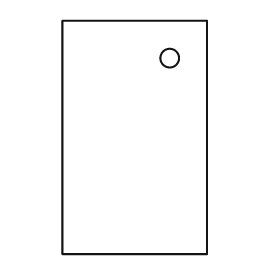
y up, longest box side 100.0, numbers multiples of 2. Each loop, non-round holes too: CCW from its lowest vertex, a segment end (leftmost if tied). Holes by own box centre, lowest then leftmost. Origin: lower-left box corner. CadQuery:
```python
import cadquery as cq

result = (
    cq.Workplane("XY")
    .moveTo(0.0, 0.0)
    .lineTo(62.0, 0.0)
    .lineTo(62.0, 100.0)
    .lineTo(0.0, 100.0)
    .close()
    .moveTo(46.0, 84.0)
    .circle(4.0)
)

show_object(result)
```